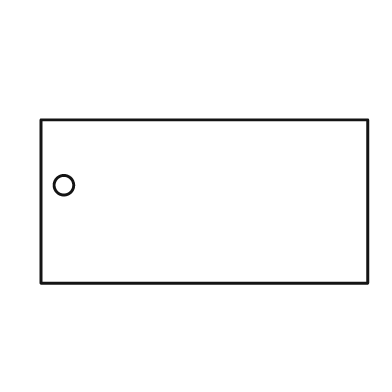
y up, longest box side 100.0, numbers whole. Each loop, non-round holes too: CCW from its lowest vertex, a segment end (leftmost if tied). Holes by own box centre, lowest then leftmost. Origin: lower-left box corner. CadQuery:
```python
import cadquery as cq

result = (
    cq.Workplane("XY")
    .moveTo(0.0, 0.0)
    .lineTo(100.0, 0.0)
    .lineTo(100.0, 50.0)
    .lineTo(0.0, 50.0)
    .close()
    .moveTo(7.0, 30.0)
    .circle(3.0)
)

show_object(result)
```